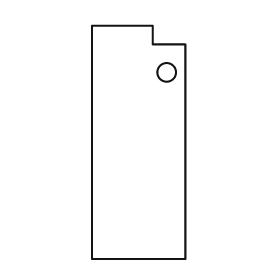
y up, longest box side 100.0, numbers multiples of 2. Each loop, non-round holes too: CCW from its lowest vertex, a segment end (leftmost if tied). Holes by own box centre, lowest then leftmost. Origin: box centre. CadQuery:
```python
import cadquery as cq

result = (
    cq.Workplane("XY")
    .moveTo(-20.0, -50.0)
    .lineTo(20.0, -50.0)
    .lineTo(20.0, 42.0)
    .lineTo(6.0, 42.0)
    .lineTo(6.0, 50.0)
    .lineTo(-20.0, 50.0)
    .close()
    .moveTo(12.0, 30.0)
    .circle(4.0)
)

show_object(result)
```